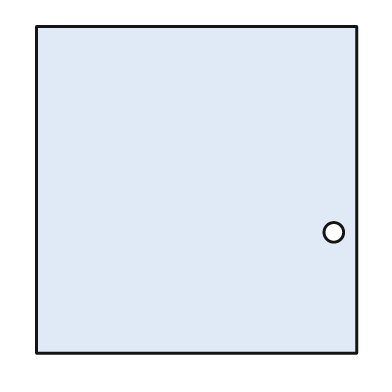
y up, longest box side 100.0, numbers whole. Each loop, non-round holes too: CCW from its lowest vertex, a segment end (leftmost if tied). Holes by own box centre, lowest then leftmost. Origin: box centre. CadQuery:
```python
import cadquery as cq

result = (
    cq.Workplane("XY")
    .moveTo(-49.0, -50.0)
    .lineTo(49.0, -50.0)
    .lineTo(49.0, 50.0)
    .lineTo(-49.0, 50.0)
    .close()
    .moveTo(42.0, -13.0)
    .circle(3.0)
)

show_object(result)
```